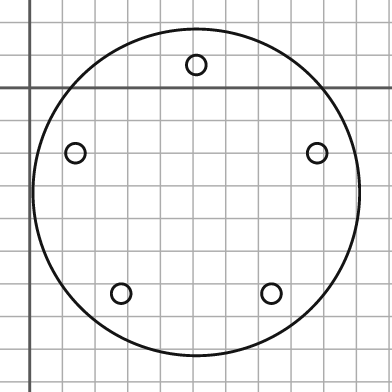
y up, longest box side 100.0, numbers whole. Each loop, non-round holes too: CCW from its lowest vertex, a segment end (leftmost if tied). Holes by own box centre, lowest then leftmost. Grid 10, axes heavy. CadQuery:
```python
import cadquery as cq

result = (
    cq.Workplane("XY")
    .moveTo(51.0, -32.0)
    .circle(50.0)
    .moveTo(28.0, -63.0)
    .circle(3.0)
    .moveTo(74.0, -63.0)
    .circle(3.0)
    .moveTo(14.0, -20.0)
    .circle(3.0)
    .moveTo(88.0, -20.0)
    .circle(3.0)
    .moveTo(51.0, 7.0)
    .circle(3.0)
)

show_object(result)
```